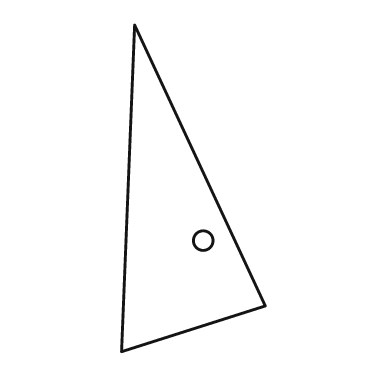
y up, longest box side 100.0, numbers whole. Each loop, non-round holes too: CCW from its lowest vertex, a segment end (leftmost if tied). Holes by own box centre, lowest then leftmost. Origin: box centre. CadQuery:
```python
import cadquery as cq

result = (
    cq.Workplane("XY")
    .moveTo(-22.0, -50.0)
    .lineTo(22.0, -36.0)
    .lineTo(-18.0, 50.0)
    .close()
    .moveTo(3.0, -16.0)
    .circle(3.0)
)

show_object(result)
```